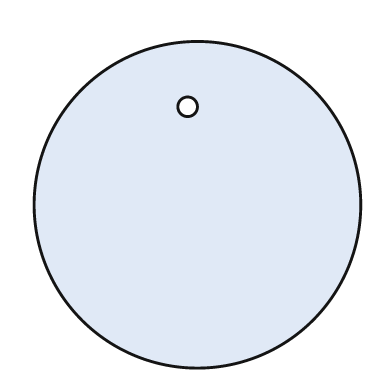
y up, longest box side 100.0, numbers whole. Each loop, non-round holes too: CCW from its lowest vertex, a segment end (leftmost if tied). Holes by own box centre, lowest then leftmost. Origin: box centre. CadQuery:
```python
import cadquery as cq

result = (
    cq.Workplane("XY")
    .moveTo(0.0, 0.0)
    .circle(50.0)
    .moveTo(-3.0, 30.0)
    .circle(3.0)
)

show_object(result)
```